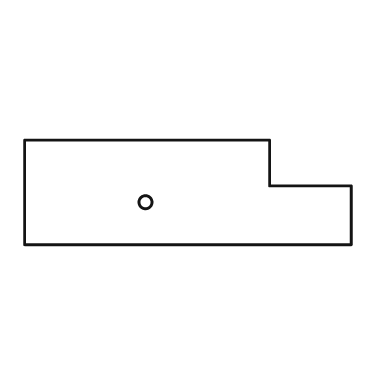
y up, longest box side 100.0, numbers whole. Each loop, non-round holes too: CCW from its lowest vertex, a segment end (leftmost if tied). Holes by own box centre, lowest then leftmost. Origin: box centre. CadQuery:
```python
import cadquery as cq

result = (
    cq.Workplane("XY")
    .moveTo(-50.0, -16.0)
    .lineTo(50.0, -16.0)
    .lineTo(50.0, 2.0)
    .lineTo(25.0, 2.0)
    .lineTo(25.0, 16.0)
    .lineTo(-50.0, 16.0)
    .close()
    .moveTo(-13.0, -3.0)
    .circle(2.0)
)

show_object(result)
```